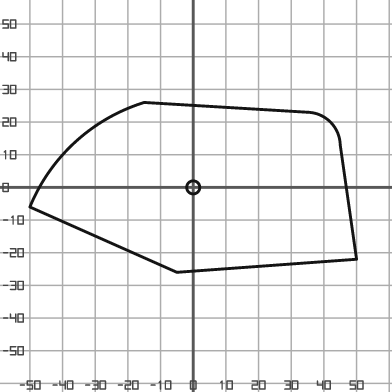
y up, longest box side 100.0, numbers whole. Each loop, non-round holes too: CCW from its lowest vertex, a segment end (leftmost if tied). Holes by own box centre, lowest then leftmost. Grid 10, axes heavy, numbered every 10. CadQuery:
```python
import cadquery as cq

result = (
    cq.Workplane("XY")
    .moveTo(-5.0, -26.0)
    .lineTo(50.0, -22.0)
    .lineTo(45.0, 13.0)
    .threePointArc((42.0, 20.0), (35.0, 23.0))
    .lineTo(-15.0, 26.0)
    .threePointArc((-36.0, 14.0), (-50.0, -6.0))
    .close()
    .moveTo(0.0, 0.0)
    .circle(2.0)
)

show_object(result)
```